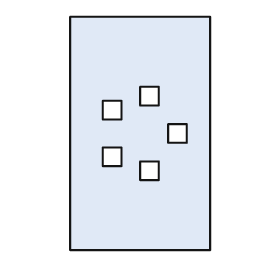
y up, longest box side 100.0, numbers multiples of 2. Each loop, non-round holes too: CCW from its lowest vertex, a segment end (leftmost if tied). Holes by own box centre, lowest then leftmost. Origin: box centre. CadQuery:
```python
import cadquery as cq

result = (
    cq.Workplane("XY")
    .moveTo(-30.0, -50.0)
    .lineTo(30.0, -50.0)
    .lineTo(30.0, 50.0)
    .lineTo(-30.0, 50.0)
    .close()
    .moveTo(0.0, -20.0)
    .lineTo(8.0, -20.0)
    .lineTo(8.0, -12.0)
    .lineTo(0.0, -12.0)
    .close()
    .moveTo(-16.0, -14.0)
    .lineTo(-8.0, -14.0)
    .lineTo(-8.0, -6.0)
    .lineTo(-16.0, -6.0)
    .close()
    .moveTo(12.0, -4.0)
    .lineTo(20.0, -4.0)
    .lineTo(20.0, 4.0)
    .lineTo(12.0, 4.0)
    .close()
    .moveTo(-16.0, 6.0)
    .lineTo(-8.0, 6.0)
    .lineTo(-8.0, 14.0)
    .lineTo(-16.0, 14.0)
    .close()
    .moveTo(0.0, 12.0)
    .lineTo(8.0, 12.0)
    .lineTo(8.0, 20.0)
    .lineTo(0.0, 20.0)
    .close()
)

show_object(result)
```